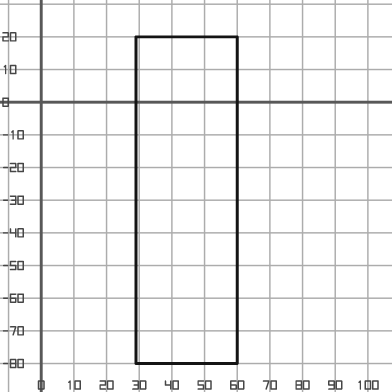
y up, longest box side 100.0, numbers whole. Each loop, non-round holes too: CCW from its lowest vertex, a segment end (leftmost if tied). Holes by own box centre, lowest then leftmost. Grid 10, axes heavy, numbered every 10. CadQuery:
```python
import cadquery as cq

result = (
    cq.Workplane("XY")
    .moveTo(29.0, -80.0)
    .lineTo(60.0, -80.0)
    .lineTo(60.0, 20.0)
    .lineTo(29.0, 20.0)
    .close()
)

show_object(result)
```